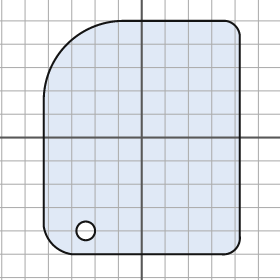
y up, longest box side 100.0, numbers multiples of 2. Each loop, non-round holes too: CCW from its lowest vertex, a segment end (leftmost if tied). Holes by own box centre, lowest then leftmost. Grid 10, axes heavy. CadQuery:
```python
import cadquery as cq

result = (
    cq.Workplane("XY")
    .moveTo(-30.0, -50.0)
    .lineTo(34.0, -50.0)
    .threePointArc((40.0, -48.0), (42.0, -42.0))
    .lineTo(42.0, 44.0)
    .threePointArc((40.0, 48.0), (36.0, 50.0))
    .lineTo(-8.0, 50.0)
    .threePointArc((-32.0, 40.0), (-42.0, 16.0))
    .lineTo(-42.0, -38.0)
    .threePointArc((-38.0, -46.0), (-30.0, -50.0))
    .close()
    .moveTo(-24.0, -40.0)
    .circle(4.0)
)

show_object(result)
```